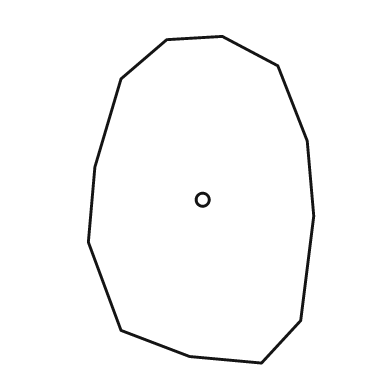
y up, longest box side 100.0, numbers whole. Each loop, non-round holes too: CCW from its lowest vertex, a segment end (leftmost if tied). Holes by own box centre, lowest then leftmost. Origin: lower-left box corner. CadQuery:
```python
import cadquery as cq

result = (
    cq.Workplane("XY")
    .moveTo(53.0, 0.0)
    .lineTo(65.0, 13.0)
    .lineTo(69.0, 45.0)
    .lineTo(67.0, 68.0)
    .lineTo(58.0, 91.0)
    .lineTo(41.0, 100.0)
    .lineTo(24.0, 99.0)
    .lineTo(10.0, 87.0)
    .lineTo(2.0, 60.0)
    .lineTo(0.0, 37.0)
    .lineTo(10.0, 10.0)
    .lineTo(31.0, 2.0)
    .close()
    .moveTo(35.0, 50.0)
    .circle(2.0)
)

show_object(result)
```